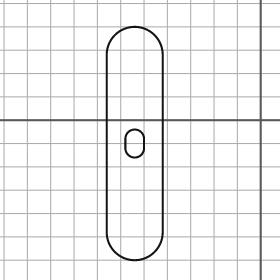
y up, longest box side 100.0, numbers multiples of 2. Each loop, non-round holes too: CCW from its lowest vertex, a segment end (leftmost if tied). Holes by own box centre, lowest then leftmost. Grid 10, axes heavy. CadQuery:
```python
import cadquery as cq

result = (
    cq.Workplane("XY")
    .moveTo(-66.0, -48.0)
    .threePointArc((-54.0, -60.0), (-42.0, -48.0))
    .lineTo(-42.0, 28.0)
    .threePointArc((-54.0, 40.0), (-66.0, 28.0))
    .close()
    .moveTo(-58.0, -12.0)
    .threePointArc((-54.0, -16.0), (-50.0, -12.0))
    .lineTo(-50.0, -8.0)
    .threePointArc((-54.0, -4.0), (-58.0, -8.0))
    .close()
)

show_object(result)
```